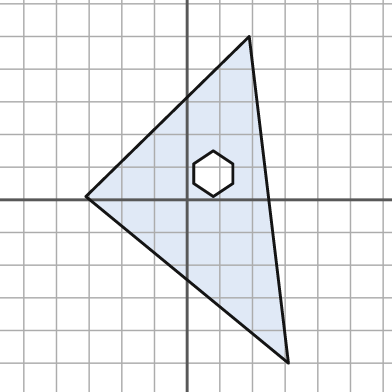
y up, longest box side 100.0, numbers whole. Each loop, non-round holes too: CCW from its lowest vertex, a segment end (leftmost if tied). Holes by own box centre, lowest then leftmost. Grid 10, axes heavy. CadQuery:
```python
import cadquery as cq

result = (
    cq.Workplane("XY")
    .moveTo(31.0, -50.0)
    .lineTo(19.0, 50.0)
    .lineTo(-31.0, 1.0)
    .close()
    .moveTo(8.0, 1.0)
    .lineTo(14.0, 5.0)
    .lineTo(14.0, 11.0)
    .lineTo(8.0, 15.0)
    .lineTo(2.0, 11.0)
    .lineTo(2.0, 5.0)
    .close()
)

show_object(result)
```